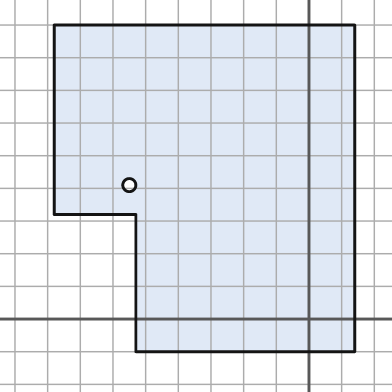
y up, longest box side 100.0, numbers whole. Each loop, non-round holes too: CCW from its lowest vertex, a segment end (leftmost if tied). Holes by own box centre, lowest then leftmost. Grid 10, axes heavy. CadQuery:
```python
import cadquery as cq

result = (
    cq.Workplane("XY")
    .moveTo(-53.0, -10.0)
    .lineTo(14.0, -10.0)
    .lineTo(14.0, 90.0)
    .lineTo(-78.0, 90.0)
    .lineTo(-78.0, 32.0)
    .lineTo(-53.0, 32.0)
    .close()
    .moveTo(-55.0, 41.0)
    .circle(2.0)
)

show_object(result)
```